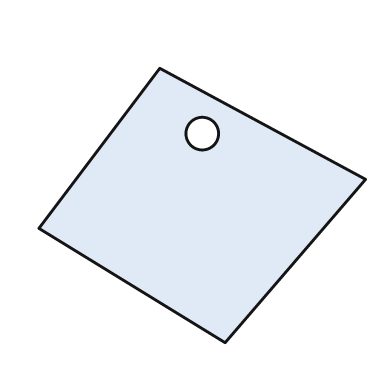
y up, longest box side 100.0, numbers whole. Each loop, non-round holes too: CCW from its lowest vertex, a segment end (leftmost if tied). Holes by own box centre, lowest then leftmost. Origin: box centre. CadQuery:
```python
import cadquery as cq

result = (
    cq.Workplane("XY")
    .moveTo(7.0, -42.0)
    .lineTo(50.0, 8.0)
    .lineTo(-13.0, 42.0)
    .lineTo(-50.0, -7.0)
    .close()
    .moveTo(0.0, 22.0)
    .circle(5.0)
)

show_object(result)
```